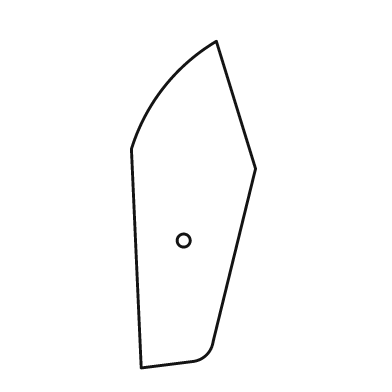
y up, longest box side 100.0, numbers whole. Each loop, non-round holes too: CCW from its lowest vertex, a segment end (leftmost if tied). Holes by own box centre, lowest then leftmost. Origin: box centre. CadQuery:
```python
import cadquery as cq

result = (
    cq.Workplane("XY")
    .moveTo(-16.0, -50.0)
    .lineTo(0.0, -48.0)
    .threePointArc((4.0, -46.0), (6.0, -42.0))
    .lineTo(19.0, 11.0)
    .lineTo(7.0, 50.0)
    .threePointArc((-9.0, 36.0), (-19.0, 17.0))
    .close()
    .moveTo(-3.0, -11.0)
    .circle(2.0)
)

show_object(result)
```